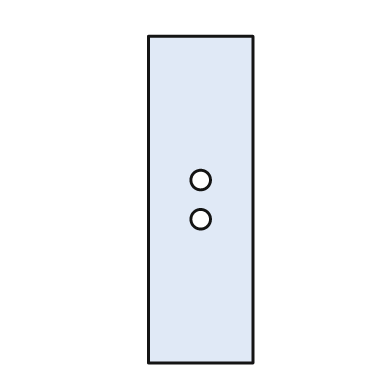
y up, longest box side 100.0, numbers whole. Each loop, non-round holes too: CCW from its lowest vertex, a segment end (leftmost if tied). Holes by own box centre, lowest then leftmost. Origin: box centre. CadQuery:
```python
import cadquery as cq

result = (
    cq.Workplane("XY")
    .moveTo(-16.0, -50.0)
    .lineTo(16.0, -50.0)
    .lineTo(16.0, 50.0)
    .lineTo(-16.0, 50.0)
    .close()
    .moveTo(0.0, -6.0)
    .circle(3.0)
    .moveTo(0.0, 6.0)
    .circle(3.0)
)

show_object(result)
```